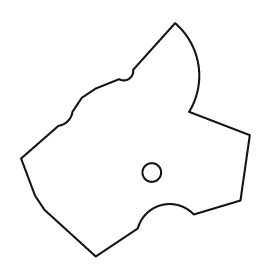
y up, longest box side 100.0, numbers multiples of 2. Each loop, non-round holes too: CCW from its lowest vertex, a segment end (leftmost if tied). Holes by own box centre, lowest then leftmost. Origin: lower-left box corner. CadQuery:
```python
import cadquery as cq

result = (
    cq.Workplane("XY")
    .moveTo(32.0, 0.0)
    .lineTo(50.0, 12.0)
    .threePointArc((60.0, 22.0), (74.0, 18.0))
    .lineTo(94.0, 24.0)
    .lineTo(98.0, 52.0)
    .lineTo(72.0, 62.0)
    .threePointArc((76.0, 82.0), (66.0, 100.0))
    .lineTo(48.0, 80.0)
    .threePointArc((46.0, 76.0), (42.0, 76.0))
    .lineTo(32.0, 72.0)
    .lineTo(26.0, 68.0)
    .lineTo(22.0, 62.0)
    .threePointArc((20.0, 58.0), (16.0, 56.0))
    .lineTo(0.0, 42.0)
    .lineTo(6.0, 26.0)
    .lineTo(10.0, 20.0)
    .close()
    .moveTo(56.0, 36.0)
    .circle(4.0)
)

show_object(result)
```